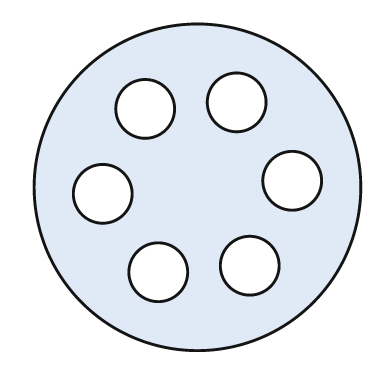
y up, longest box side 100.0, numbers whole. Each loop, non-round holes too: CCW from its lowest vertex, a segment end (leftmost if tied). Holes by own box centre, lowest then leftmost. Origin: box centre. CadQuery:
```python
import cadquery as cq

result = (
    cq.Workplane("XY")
    .moveTo(0.0, 0.0)
    .circle(50.0)
    .moveTo(-12.0, -26.0)
    .circle(9.0)
    .moveTo(16.0, -24.0)
    .circle(9.0)
    .moveTo(-29.0, -2.0)
    .circle(9.0)
    .moveTo(29.0, 2.0)
    .circle(9.0)
    .moveTo(-16.0, 24.0)
    .circle(9.0)
    .moveTo(12.0, 26.0)
    .circle(9.0)
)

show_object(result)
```